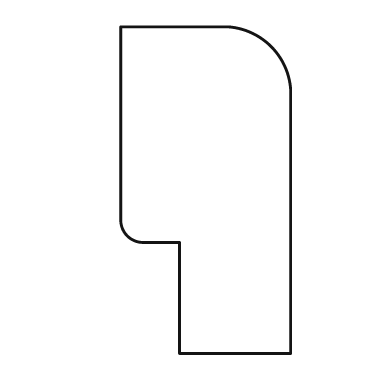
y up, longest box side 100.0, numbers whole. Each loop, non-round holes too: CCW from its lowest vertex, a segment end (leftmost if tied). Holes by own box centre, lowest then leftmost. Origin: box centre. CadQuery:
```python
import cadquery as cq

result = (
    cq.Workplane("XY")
    .moveTo(-8.0, -50.0)
    .lineTo(26.0, -50.0)
    .lineTo(26.0, 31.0)
    .threePointArc((20.0, 44.0), (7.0, 50.0))
    .lineTo(-26.0, 50.0)
    .lineTo(-26.0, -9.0)
    .threePointArc((-24.0, -14.0), (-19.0, -16.0))
    .lineTo(-8.0, -16.0)
    .close()
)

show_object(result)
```